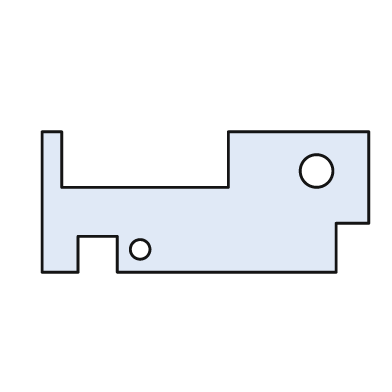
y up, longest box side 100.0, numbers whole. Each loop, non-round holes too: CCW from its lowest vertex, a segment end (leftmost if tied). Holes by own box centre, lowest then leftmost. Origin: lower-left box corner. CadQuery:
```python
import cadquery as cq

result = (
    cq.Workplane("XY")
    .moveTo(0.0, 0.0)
    .lineTo(11.0, 0.0)
    .lineTo(11.0, 11.0)
    .lineTo(23.0, 11.0)
    .lineTo(23.0, 0.0)
    .lineTo(90.0, 0.0)
    .lineTo(90.0, 15.0)
    .lineTo(100.0, 15.0)
    .lineTo(100.0, 43.0)
    .lineTo(57.0, 43.0)
    .lineTo(57.0, 26.0)
    .lineTo(6.0, 26.0)
    .lineTo(6.0, 43.0)
    .lineTo(0.0, 43.0)
    .close()
    .moveTo(30.0, 7.0)
    .circle(3.0)
    .moveTo(84.0, 31.0)
    .circle(5.0)
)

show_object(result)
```